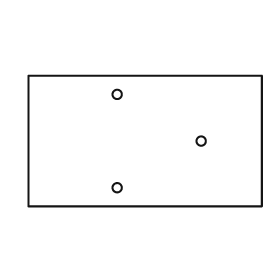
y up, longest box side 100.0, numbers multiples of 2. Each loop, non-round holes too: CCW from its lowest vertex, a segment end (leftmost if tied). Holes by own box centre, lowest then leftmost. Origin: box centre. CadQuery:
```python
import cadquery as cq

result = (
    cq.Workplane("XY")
    .moveTo(-50.0, -28.0)
    .lineTo(50.0, -28.0)
    .lineTo(50.0, 28.0)
    .lineTo(-50.0, 28.0)
    .close()
    .moveTo(-12.0, -20.0)
    .circle(2.0)
    .moveTo(24.0, 0.0)
    .circle(2.0)
    .moveTo(-12.0, 20.0)
    .circle(2.0)
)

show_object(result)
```